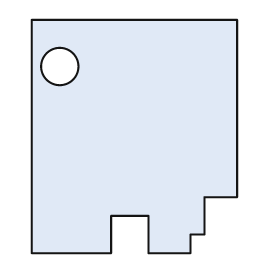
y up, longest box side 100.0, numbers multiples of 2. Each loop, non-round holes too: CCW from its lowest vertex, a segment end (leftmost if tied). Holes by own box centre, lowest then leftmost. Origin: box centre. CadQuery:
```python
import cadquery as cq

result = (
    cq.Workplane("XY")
    .moveTo(-44.0, -50.0)
    .lineTo(-10.0, -50.0)
    .lineTo(-10.0, -34.0)
    .lineTo(6.0, -34.0)
    .lineTo(6.0, -50.0)
    .lineTo(24.0, -50.0)
    .lineTo(24.0, -42.0)
    .lineTo(30.0, -42.0)
    .lineTo(30.0, -26.0)
    .lineTo(44.0, -26.0)
    .lineTo(44.0, 50.0)
    .lineTo(-44.0, 50.0)
    .close()
    .moveTo(-32.0, 30.0)
    .circle(8.0)
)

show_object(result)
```